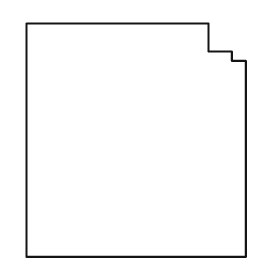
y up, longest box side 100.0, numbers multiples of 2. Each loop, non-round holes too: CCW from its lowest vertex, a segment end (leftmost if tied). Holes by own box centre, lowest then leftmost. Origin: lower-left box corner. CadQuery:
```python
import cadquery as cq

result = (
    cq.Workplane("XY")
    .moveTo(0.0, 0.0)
    .lineTo(94.0, 0.0)
    .lineTo(94.0, 84.0)
    .lineTo(88.0, 84.0)
    .lineTo(88.0, 88.0)
    .lineTo(78.0, 88.0)
    .lineTo(78.0, 100.0)
    .lineTo(0.0, 100.0)
    .close()
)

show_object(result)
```